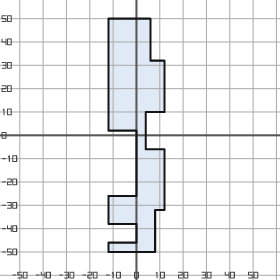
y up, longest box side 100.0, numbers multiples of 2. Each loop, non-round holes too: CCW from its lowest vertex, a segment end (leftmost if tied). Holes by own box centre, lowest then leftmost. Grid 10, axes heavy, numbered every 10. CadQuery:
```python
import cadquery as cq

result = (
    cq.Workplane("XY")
    .moveTo(-12.0, -50.0)
    .lineTo(8.0, -50.0)
    .lineTo(8.0, -32.0)
    .lineTo(12.0, -32.0)
    .lineTo(12.0, -6.0)
    .lineTo(4.0, -6.0)
    .lineTo(4.0, 10.0)
    .lineTo(12.0, 10.0)
    .lineTo(12.0, 32.0)
    .lineTo(6.0, 32.0)
    .lineTo(6.0, 50.0)
    .lineTo(-12.0, 50.0)
    .lineTo(-12.0, 2.0)
    .lineTo(0.0, 2.0)
    .lineTo(0.0, -26.0)
    .lineTo(-12.0, -26.0)
    .lineTo(-12.0, -38.0)
    .lineTo(0.0, -38.0)
    .lineTo(0.0, -46.0)
    .lineTo(-12.0, -46.0)
    .close()
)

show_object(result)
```